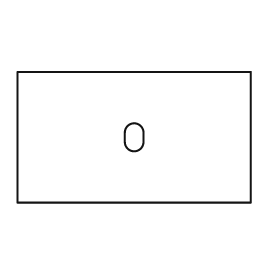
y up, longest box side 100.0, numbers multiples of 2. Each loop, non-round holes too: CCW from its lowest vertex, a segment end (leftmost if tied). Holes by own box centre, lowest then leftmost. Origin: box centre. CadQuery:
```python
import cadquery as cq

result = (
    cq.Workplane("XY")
    .moveTo(-50.0, -28.0)
    .lineTo(50.0, -28.0)
    .lineTo(50.0, 28.0)
    .lineTo(-50.0, 28.0)
    .close()
    .moveTo(-4.0, -2.0)
    .threePointArc((0.0, -6.0), (4.0, -2.0))
    .lineTo(4.0, 2.0)
    .threePointArc((0.0, 6.0), (-4.0, 2.0))
    .close()
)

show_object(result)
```